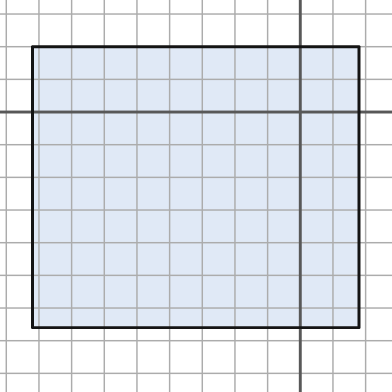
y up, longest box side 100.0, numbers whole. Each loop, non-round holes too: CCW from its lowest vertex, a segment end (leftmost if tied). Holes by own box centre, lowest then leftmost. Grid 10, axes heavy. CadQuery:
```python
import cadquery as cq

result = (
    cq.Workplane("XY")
    .moveTo(-82.0, -66.0)
    .lineTo(18.0, -66.0)
    .lineTo(18.0, 20.0)
    .lineTo(-82.0, 20.0)
    .close()
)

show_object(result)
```